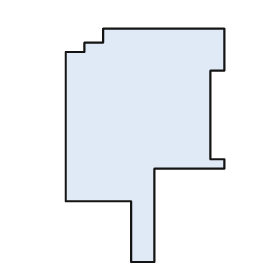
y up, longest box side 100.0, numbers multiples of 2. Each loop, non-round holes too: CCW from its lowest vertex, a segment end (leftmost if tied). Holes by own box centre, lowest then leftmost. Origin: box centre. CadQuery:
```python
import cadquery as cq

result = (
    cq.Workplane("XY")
    .moveTo(-6.0, -50.0)
    .lineTo(4.0, -50.0)
    .lineTo(4.0, -10.0)
    .lineTo(34.0, -10.0)
    .lineTo(34.0, -6.0)
    .lineTo(28.0, -6.0)
    .lineTo(28.0, 32.0)
    .lineTo(34.0, 32.0)
    .lineTo(34.0, 50.0)
    .lineTo(-18.0, 50.0)
    .lineTo(-18.0, 44.0)
    .lineTo(-26.0, 44.0)
    .lineTo(-26.0, 40.0)
    .lineTo(-34.0, 40.0)
    .lineTo(-34.0, -24.0)
    .lineTo(-6.0, -24.0)
    .close()
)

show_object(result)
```